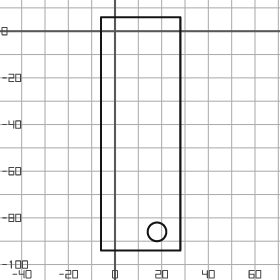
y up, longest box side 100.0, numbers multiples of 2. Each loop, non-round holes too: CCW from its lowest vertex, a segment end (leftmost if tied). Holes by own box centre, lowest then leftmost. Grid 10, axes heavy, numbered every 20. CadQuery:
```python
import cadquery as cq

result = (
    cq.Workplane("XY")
    .moveTo(-6.0, -94.0)
    .lineTo(28.0, -94.0)
    .lineTo(28.0, 6.0)
    .lineTo(-6.0, 6.0)
    .close()
    .moveTo(18.0, -86.0)
    .circle(4.0)
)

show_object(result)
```